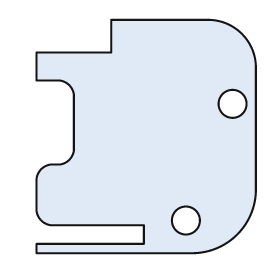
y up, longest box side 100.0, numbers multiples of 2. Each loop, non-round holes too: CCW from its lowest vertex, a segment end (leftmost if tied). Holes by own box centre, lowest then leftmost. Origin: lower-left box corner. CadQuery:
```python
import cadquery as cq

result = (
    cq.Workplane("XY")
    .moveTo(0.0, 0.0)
    .lineTo(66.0, 0.0)
    .threePointArc((86.0, 8.0), (94.0, 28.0))
    .lineTo(94.0, 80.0)
    .threePointArc((88.0, 94.0), (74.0, 100.0))
    .lineTo(32.0, 100.0)
    .lineTo(32.0, 86.0)
    .lineTo(0.0, 86.0)
    .lineTo(0.0, 74.0)
    .lineTo(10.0, 74.0)
    .threePointArc((14.0, 72.0), (16.0, 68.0))
    .lineTo(16.0, 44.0)
    .threePointArc((14.0, 40.0), (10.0, 38.0))
    .lineTo(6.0, 38.0)
    .threePointArc((2.0, 36.0), (0.0, 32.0))
    .lineTo(0.0, 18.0)
    .threePointArc((2.0, 14.0), (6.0, 12.0))
    .lineTo(46.0, 12.0)
    .lineTo(46.0, 4.0)
    .lineTo(0.0, 4.0)
    .close()
    .moveTo(64.0, 14.0)
    .circle(6.0)
    .moveTo(84.0, 64.0)
    .circle(6.0)
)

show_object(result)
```